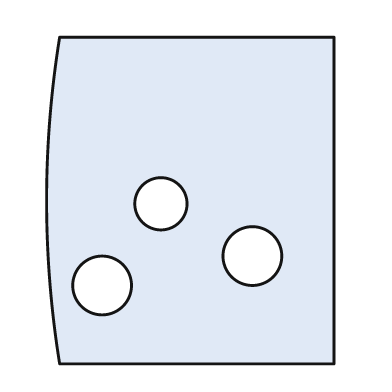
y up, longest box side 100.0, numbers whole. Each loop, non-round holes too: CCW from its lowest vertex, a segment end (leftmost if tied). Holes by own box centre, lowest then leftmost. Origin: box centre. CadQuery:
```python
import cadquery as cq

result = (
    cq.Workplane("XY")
    .moveTo(-40.0, -50.0)
    .lineTo(44.0, -50.0)
    .lineTo(44.0, 50.0)
    .lineTo(-40.0, 50.0)
    .threePointArc((-44.0, 0.0), (-40.0, -50.0))
    .close()
    .moveTo(-27.0, -26.0)
    .circle(9.0)
    .moveTo(19.0, -17.0)
    .circle(9.0)
    .moveTo(-9.0, -1.0)
    .circle(8.0)
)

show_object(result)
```